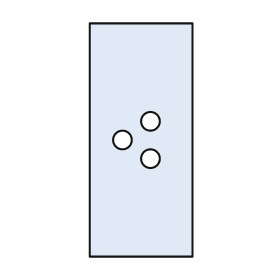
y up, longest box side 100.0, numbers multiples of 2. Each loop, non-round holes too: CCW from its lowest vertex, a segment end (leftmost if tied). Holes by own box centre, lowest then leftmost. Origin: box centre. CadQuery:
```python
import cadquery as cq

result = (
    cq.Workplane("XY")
    .moveTo(-22.0, -50.0)
    .lineTo(22.0, -50.0)
    .lineTo(22.0, 50.0)
    .lineTo(-22.0, 50.0)
    .close()
    .moveTo(4.0, -8.0)
    .circle(4.0)
    .moveTo(-8.0, 0.0)
    .circle(4.0)
    .moveTo(4.0, 8.0)
    .circle(4.0)
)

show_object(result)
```